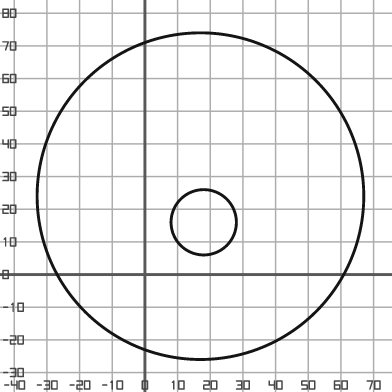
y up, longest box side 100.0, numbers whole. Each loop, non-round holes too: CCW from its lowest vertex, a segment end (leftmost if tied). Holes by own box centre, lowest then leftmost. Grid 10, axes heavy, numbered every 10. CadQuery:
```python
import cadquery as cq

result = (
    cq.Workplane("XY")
    .moveTo(17.0, 24.0)
    .circle(50.0)
    .moveTo(18.0, 16.0)
    .circle(10.0)
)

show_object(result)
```